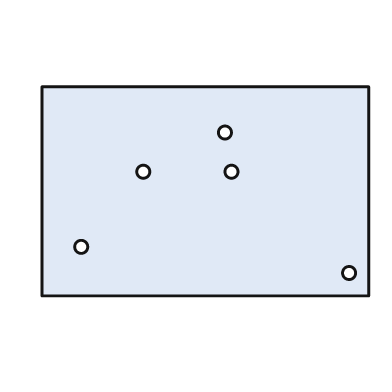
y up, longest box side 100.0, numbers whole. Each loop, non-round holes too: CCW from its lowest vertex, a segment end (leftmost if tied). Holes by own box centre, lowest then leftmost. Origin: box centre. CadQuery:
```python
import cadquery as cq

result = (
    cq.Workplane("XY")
    .moveTo(-50.0, -32.0)
    .lineTo(50.0, -32.0)
    .lineTo(50.0, 32.0)
    .lineTo(-50.0, 32.0)
    .close()
    .moveTo(44.0, -25.0)
    .circle(2.0)
    .moveTo(-38.0, -17.0)
    .circle(2.0)
    .moveTo(-19.0, 6.0)
    .circle(2.0)
    .moveTo(8.0, 6.0)
    .circle(2.0)
    .moveTo(6.0, 18.0)
    .circle(2.0)
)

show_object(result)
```